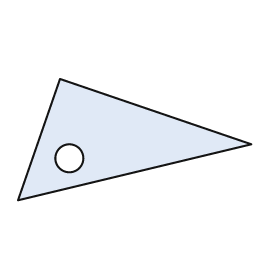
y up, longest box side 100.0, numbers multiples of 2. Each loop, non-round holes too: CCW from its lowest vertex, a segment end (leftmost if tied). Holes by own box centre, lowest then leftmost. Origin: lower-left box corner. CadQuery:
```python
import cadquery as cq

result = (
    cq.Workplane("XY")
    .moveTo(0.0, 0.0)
    .lineTo(100.0, 24.0)
    .lineTo(18.0, 52.0)
    .close()
    .moveTo(22.0, 18.0)
    .circle(6.0)
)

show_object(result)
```